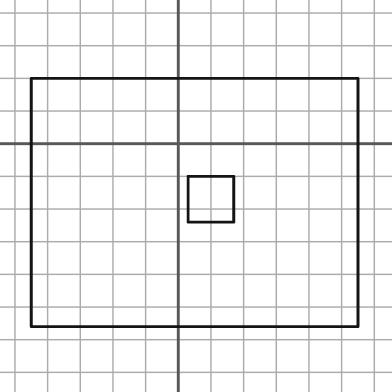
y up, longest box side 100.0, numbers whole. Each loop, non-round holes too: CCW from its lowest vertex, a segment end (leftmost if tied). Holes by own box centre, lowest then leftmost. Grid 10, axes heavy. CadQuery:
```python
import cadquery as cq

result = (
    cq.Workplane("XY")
    .moveTo(-45.0, -56.0)
    .lineTo(55.0, -56.0)
    .lineTo(55.0, 20.0)
    .lineTo(-45.0, 20.0)
    .close()
    .moveTo(3.0, -24.0)
    .lineTo(17.0, -24.0)
    .lineTo(17.0, -10.0)
    .lineTo(3.0, -10.0)
    .close()
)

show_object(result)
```